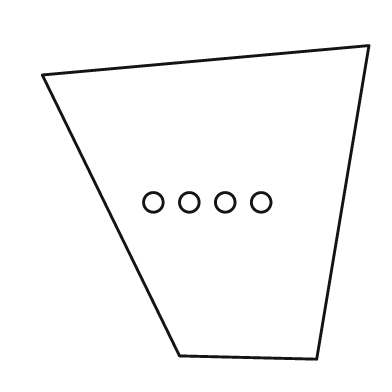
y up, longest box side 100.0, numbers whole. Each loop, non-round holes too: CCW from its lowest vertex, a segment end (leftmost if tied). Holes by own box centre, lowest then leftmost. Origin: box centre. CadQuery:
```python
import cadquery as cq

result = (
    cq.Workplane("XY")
    .moveTo(34.0, -48.0)
    .lineTo(50.0, 48.0)
    .lineTo(-50.0, 39.0)
    .lineTo(-8.0, -47.0)
    .close()
    .moveTo(-16.0, 0.0)
    .circle(3.0)
    .moveTo(-5.0, 0.0)
    .circle(3.0)
    .moveTo(6.0, 0.0)
    .circle(3.0)
    .moveTo(17.0, 0.0)
    .circle(3.0)
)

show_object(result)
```